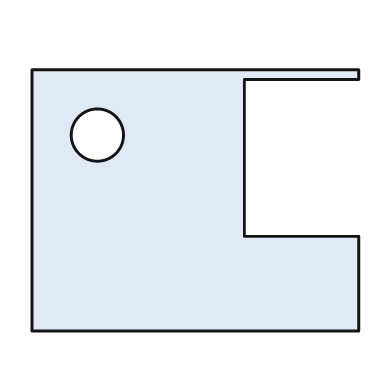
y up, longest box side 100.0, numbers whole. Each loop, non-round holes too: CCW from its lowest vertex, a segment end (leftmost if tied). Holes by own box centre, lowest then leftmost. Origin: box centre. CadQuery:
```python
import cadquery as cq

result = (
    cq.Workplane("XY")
    .moveTo(-50.0, -40.0)
    .lineTo(50.0, -40.0)
    .lineTo(50.0, -11.0)
    .lineTo(15.0, -11.0)
    .lineTo(15.0, 37.0)
    .lineTo(50.0, 37.0)
    .lineTo(50.0, 40.0)
    .lineTo(-50.0, 40.0)
    .close()
    .moveTo(-30.0, 20.0)
    .circle(8.0)
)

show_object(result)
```